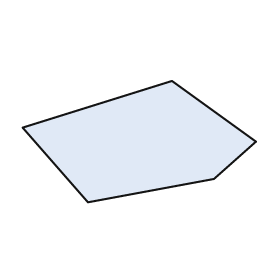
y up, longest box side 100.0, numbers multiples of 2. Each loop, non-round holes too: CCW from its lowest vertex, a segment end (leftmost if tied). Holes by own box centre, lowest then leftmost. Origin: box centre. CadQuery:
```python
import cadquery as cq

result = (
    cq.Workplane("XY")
    .moveTo(-22.0, -26.0)
    .lineTo(32.0, -16.0)
    .lineTo(50.0, 0.0)
    .lineTo(14.0, 26.0)
    .lineTo(-50.0, 6.0)
    .close()
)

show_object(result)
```